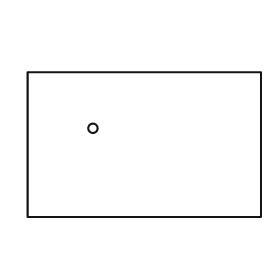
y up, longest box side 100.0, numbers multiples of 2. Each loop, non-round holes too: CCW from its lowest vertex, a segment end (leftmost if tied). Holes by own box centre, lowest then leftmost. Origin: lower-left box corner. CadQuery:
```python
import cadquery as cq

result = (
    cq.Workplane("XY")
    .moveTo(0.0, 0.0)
    .lineTo(100.0, 0.0)
    .lineTo(100.0, 62.0)
    .lineTo(0.0, 62.0)
    .close()
    .moveTo(28.0, 38.0)
    .circle(2.0)
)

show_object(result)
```